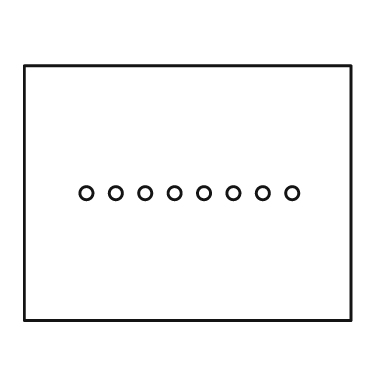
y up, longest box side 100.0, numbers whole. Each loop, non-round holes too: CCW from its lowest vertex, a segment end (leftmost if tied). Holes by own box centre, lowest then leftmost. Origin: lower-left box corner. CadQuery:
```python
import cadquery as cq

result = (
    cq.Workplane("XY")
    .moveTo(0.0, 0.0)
    .lineTo(100.0, 0.0)
    .lineTo(100.0, 78.0)
    .lineTo(0.0, 78.0)
    .close()
    .moveTo(19.0, 39.0)
    .circle(2.0)
    .moveTo(28.0, 39.0)
    .circle(2.0)
    .moveTo(37.0, 39.0)
    .circle(2.0)
    .moveTo(46.0, 39.0)
    .circle(2.0)
    .moveTo(55.0, 39.0)
    .circle(2.0)
    .moveTo(64.0, 39.0)
    .circle(2.0)
    .moveTo(73.0, 39.0)
    .circle(2.0)
    .moveTo(82.0, 39.0)
    .circle(2.0)
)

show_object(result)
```